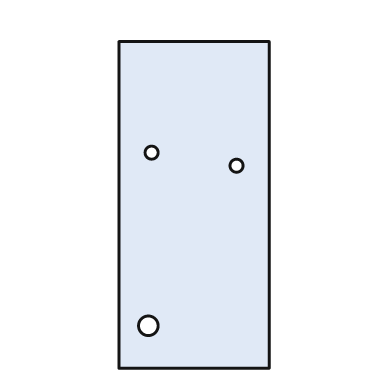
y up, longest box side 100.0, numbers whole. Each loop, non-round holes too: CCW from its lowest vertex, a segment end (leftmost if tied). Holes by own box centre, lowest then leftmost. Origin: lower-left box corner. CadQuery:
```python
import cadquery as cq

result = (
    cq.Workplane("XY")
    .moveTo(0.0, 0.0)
    .lineTo(46.0, 0.0)
    .lineTo(46.0, 100.0)
    .lineTo(0.0, 100.0)
    .close()
    .moveTo(9.0, 13.0)
    .circle(3.0)
    .moveTo(36.0, 62.0)
    .circle(2.0)
    .moveTo(10.0, 66.0)
    .circle(2.0)
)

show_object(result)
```